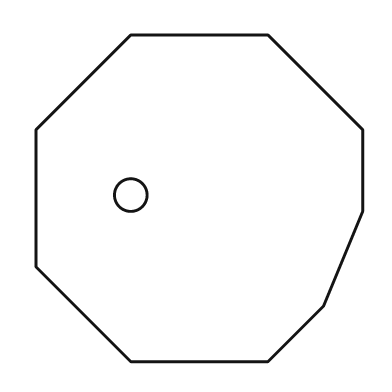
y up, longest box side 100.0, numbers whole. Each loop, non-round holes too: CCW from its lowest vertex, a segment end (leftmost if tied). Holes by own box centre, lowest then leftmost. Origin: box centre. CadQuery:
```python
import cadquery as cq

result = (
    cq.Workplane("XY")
    .moveTo(-21.0, -50.0)
    .lineTo(21.0, -50.0)
    .lineTo(38.0, -33.0)
    .lineTo(50.0, -4.0)
    .lineTo(50.0, 21.0)
    .lineTo(21.0, 50.0)
    .lineTo(-21.0, 50.0)
    .lineTo(-50.0, 21.0)
    .lineTo(-50.0, -21.0)
    .close()
    .moveTo(-21.0, 1.0)
    .circle(5.0)
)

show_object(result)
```